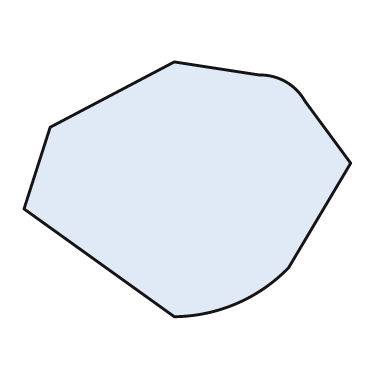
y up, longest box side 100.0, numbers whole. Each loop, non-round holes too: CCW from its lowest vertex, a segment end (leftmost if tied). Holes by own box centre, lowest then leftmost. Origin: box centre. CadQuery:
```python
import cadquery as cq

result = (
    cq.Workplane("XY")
    .moveTo(-4.0, -39.0)
    .threePointArc((15.0, -35.0), (31.0, -24.0))
    .lineTo(50.0, 8.0)
    .lineTo(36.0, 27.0)
    .threePointArc((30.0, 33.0), (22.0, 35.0))
    .lineTo(-4.0, 39.0)
    .lineTo(-42.0, 19.0)
    .lineTo(-50.0, -6.0)
    .close()
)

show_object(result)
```